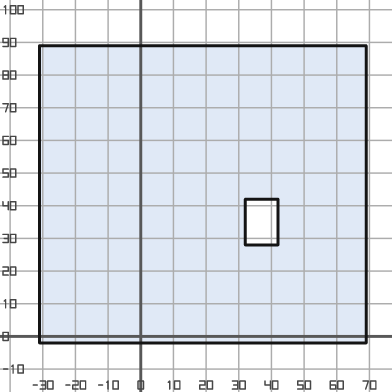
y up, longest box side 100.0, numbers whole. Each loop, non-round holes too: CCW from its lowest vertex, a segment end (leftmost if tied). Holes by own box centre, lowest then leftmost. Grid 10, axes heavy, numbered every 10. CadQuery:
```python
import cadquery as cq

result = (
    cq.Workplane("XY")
    .moveTo(-31.0, -2.0)
    .lineTo(69.0, -2.0)
    .lineTo(69.0, 89.0)
    .lineTo(-31.0, 89.0)
    .close()
    .moveTo(32.0, 28.0)
    .lineTo(42.0, 28.0)
    .lineTo(42.0, 42.0)
    .lineTo(32.0, 42.0)
    .close()
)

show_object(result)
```